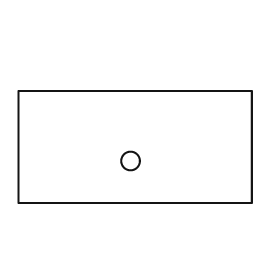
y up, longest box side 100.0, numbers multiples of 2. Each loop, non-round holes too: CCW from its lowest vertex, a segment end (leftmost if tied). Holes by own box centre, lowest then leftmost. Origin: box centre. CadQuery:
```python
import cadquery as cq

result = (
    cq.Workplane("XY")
    .moveTo(-50.0, -24.0)
    .lineTo(50.0, -24.0)
    .lineTo(50.0, 24.0)
    .lineTo(-50.0, 24.0)
    .close()
    .moveTo(-2.0, -6.0)
    .circle(4.0)
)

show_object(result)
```